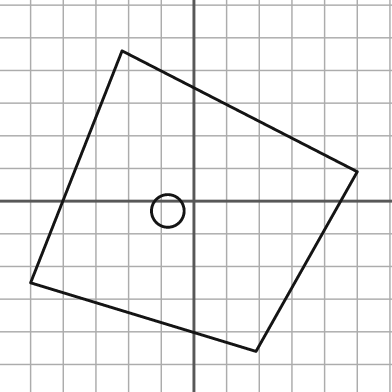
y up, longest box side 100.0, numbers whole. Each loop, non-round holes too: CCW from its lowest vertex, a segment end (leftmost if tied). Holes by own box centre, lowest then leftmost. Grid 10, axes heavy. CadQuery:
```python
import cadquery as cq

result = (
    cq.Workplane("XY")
    .moveTo(19.0, -46.0)
    .lineTo(50.0, 9.0)
    .lineTo(-22.0, 46.0)
    .lineTo(-50.0, -25.0)
    .close()
    .moveTo(-8.0, -3.0)
    .circle(5.0)
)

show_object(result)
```